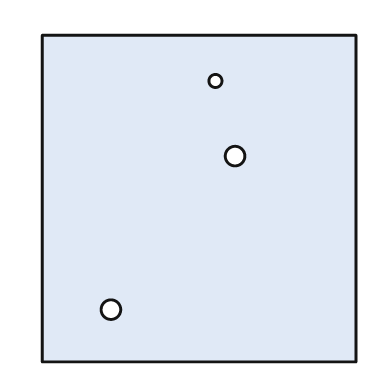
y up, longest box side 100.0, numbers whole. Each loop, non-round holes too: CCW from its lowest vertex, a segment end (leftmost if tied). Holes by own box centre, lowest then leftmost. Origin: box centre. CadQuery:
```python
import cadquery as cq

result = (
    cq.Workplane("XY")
    .moveTo(-48.0, -50.0)
    .lineTo(48.0, -50.0)
    .lineTo(48.0, 50.0)
    .lineTo(-48.0, 50.0)
    .close()
    .moveTo(-27.0, -34.0)
    .circle(3.0)
    .moveTo(11.0, 13.0)
    .circle(3.0)
    .moveTo(5.0, 36.0)
    .circle(2.0)
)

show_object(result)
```